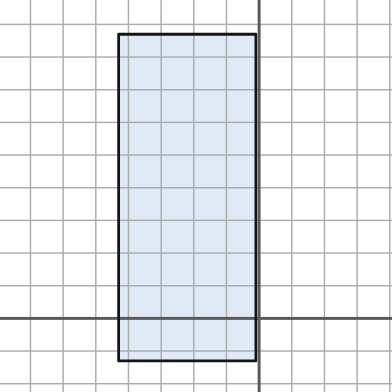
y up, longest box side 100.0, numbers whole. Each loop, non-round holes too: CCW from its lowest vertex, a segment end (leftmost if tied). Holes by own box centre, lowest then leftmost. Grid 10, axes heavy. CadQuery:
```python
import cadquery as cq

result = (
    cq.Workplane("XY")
    .moveTo(-43.0, -13.0)
    .lineTo(-1.0, -13.0)
    .lineTo(-1.0, 87.0)
    .lineTo(-43.0, 87.0)
    .close()
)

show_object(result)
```